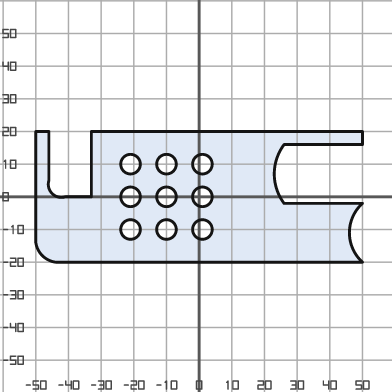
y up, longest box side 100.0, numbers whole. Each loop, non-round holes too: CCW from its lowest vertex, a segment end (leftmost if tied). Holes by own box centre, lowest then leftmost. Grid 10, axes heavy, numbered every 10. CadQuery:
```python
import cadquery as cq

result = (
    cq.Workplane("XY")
    .moveTo(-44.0, -20.0)
    .lineTo(50.0, -20.0)
    .threePointArc((46.0, -11.0), (50.0, -2.0))
    .lineTo(26.0, -2.0)
    .threePointArc((23.0, 7.0), (26.0, 16.0))
    .lineTo(50.0, 16.0)
    .lineTo(50.0, 20.0)
    .lineTo(-33.0, 20.0)
    .lineTo(-33.0, 0.0)
    .lineTo(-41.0, 0.0)
    .threePointArc((-45.0, 1.0), (-46.0, 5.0))
    .lineTo(-46.0, 20.0)
    .lineTo(-50.0, 20.0)
    .lineTo(-50.0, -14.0)
    .threePointArc((-48.0, -18.0), (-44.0, -20.0))
    .close()
    .moveTo(-21.0, -10.0)
    .circle(3.0)
    .moveTo(-10.0, -10.0)
    .circle(3.0)
    .moveTo(1.0, -10.0)
    .circle(3.0)
    .moveTo(-21.0, 0.0)
    .circle(3.0)
    .moveTo(-10.0, 0.0)
    .circle(3.0)
    .moveTo(1.0, 0.0)
    .circle(3.0)
    .moveTo(-21.0, 10.0)
    .circle(3.0)
    .moveTo(-10.0, 10.0)
    .circle(3.0)
    .moveTo(1.0, 10.0)
    .circle(3.0)
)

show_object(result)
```